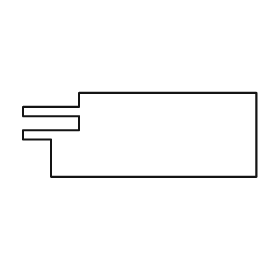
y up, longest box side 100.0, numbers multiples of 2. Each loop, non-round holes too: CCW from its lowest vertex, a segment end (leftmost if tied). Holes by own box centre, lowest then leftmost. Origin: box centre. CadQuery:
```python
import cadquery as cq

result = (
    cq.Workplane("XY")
    .moveTo(-38.0, -18.0)
    .lineTo(50.0, -18.0)
    .lineTo(50.0, 18.0)
    .lineTo(-26.0, 18.0)
    .lineTo(-26.0, 12.0)
    .lineTo(-50.0, 12.0)
    .lineTo(-50.0, 8.0)
    .lineTo(-26.0, 8.0)
    .lineTo(-26.0, 2.0)
    .lineTo(-50.0, 2.0)
    .lineTo(-50.0, -2.0)
    .lineTo(-38.0, -2.0)
    .close()
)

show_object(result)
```